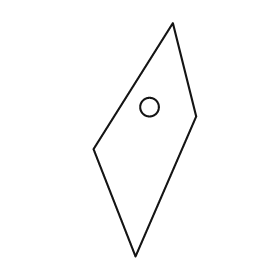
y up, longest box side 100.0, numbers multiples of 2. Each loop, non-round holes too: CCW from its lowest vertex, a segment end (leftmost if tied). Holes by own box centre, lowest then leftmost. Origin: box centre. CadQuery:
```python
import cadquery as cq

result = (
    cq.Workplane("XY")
    .moveTo(-4.0, -50.0)
    .lineTo(22.0, 10.0)
    .lineTo(12.0, 50.0)
    .lineTo(-22.0, -4.0)
    .close()
    .moveTo(2.0, 14.0)
    .circle(4.0)
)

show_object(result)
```